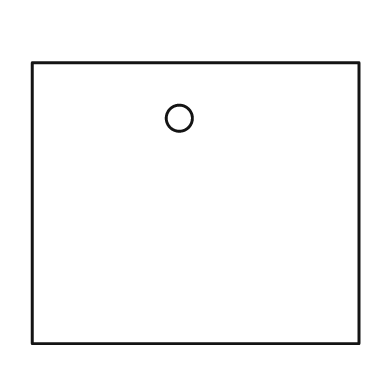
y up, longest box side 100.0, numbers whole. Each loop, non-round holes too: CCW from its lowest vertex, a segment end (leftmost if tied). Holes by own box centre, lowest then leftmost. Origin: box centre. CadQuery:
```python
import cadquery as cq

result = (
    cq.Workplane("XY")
    .moveTo(-50.0, -43.0)
    .lineTo(50.0, -43.0)
    .lineTo(50.0, 43.0)
    .lineTo(-50.0, 43.0)
    .close()
    .moveTo(-5.0, 26.0)
    .circle(4.0)
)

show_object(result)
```